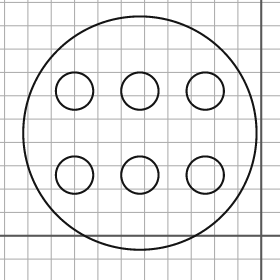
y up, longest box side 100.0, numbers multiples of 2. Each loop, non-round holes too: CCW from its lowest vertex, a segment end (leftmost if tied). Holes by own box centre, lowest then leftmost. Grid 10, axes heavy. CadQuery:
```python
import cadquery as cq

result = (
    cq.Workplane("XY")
    .moveTo(-52.0, 44.0)
    .circle(50.0)
    .moveTo(-80.0, 26.0)
    .circle(8.0)
    .moveTo(-52.0, 26.0)
    .circle(8.0)
    .moveTo(-24.0, 26.0)
    .circle(8.0)
    .moveTo(-80.0, 62.0)
    .circle(8.0)
    .moveTo(-52.0, 62.0)
    .circle(8.0)
    .moveTo(-24.0, 62.0)
    .circle(8.0)
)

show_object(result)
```